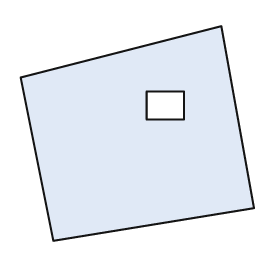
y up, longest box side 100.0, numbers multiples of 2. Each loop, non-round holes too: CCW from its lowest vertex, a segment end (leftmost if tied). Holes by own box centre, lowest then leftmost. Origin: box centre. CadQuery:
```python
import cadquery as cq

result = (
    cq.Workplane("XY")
    .moveTo(-36.0, -46.0)
    .lineTo(50.0, -32.0)
    .lineTo(36.0, 46.0)
    .lineTo(-50.0, 24.0)
    .close()
    .moveTo(4.0, 6.0)
    .lineTo(20.0, 6.0)
    .lineTo(20.0, 18.0)
    .lineTo(4.0, 18.0)
    .close()
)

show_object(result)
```